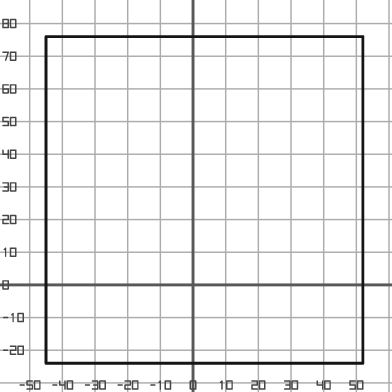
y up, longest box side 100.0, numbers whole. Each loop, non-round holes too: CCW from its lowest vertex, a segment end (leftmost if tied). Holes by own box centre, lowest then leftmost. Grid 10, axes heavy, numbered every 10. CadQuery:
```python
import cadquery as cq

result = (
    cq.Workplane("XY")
    .moveTo(-45.0, -24.0)
    .lineTo(52.0, -24.0)
    .lineTo(52.0, 76.0)
    .lineTo(-45.0, 76.0)
    .close()
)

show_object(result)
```